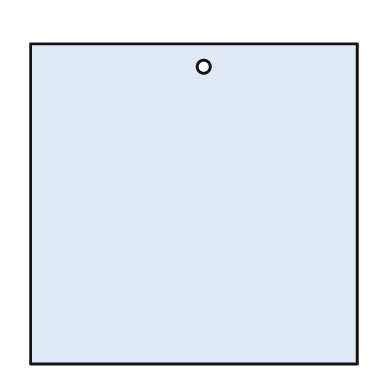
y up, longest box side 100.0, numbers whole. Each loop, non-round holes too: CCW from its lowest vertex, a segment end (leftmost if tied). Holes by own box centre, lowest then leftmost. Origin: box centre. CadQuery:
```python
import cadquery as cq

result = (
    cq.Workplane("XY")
    .moveTo(-50.0, -49.0)
    .lineTo(50.0, -49.0)
    .lineTo(50.0, 49.0)
    .lineTo(-50.0, 49.0)
    .close()
    .moveTo(3.0, 42.0)
    .circle(2.0)
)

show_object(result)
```